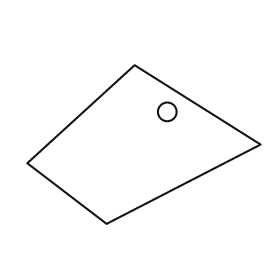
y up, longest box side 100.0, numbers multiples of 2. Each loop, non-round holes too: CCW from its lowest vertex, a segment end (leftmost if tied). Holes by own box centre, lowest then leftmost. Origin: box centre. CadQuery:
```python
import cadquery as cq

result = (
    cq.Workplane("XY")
    .moveTo(-16.0, -34.0)
    .lineTo(50.0, 0.0)
    .lineTo(-4.0, 34.0)
    .lineTo(-50.0, -8.0)
    .close()
    .moveTo(10.0, 14.0)
    .circle(4.0)
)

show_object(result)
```